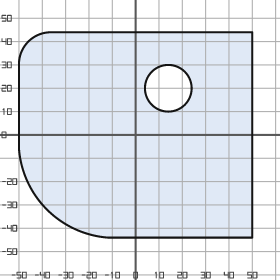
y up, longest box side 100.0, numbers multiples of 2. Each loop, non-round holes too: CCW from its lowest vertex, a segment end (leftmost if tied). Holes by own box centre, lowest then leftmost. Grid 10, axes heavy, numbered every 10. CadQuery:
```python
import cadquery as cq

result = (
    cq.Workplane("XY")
    .moveTo(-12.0, -44.0)
    .lineTo(50.0, -44.0)
    .lineTo(50.0, 44.0)
    .lineTo(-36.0, 44.0)
    .threePointArc((-46.0, 40.0), (-50.0, 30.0))
    .lineTo(-50.0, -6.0)
    .threePointArc((-38.0, -32.0), (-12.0, -44.0))
    .close()
    .moveTo(14.0, 20.0)
    .circle(10.0)
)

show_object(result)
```